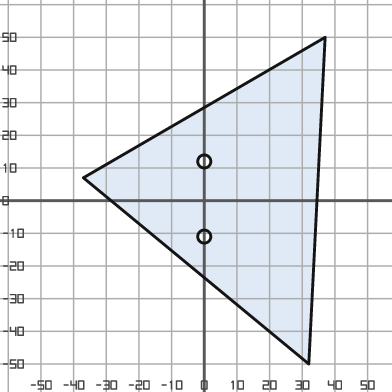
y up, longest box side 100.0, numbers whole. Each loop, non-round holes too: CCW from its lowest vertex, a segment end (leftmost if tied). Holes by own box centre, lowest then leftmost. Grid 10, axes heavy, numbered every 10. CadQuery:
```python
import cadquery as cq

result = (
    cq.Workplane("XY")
    .moveTo(32.0, -50.0)
    .lineTo(37.0, 50.0)
    .lineTo(-37.0, 7.0)
    .close()
    .moveTo(0.0, -11.0)
    .circle(2.0)
    .moveTo(0.0, 12.0)
    .circle(2.0)
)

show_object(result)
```